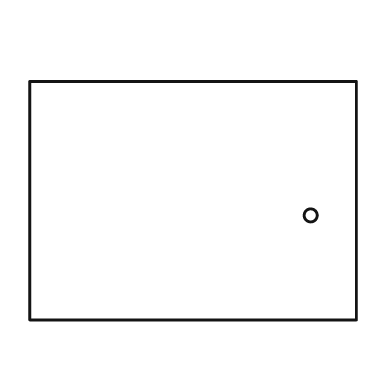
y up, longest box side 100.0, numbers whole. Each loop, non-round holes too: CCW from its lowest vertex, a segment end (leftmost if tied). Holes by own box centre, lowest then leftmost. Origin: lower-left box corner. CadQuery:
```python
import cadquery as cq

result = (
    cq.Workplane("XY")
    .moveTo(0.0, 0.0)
    .lineTo(100.0, 0.0)
    .lineTo(100.0, 73.0)
    .lineTo(0.0, 73.0)
    .close()
    .moveTo(86.0, 32.0)
    .circle(2.0)
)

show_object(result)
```